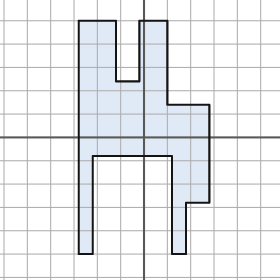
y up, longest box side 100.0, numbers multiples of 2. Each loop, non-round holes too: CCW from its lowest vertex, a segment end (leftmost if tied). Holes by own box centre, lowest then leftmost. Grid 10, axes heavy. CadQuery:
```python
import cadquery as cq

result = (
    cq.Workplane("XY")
    .moveTo(-28.0, -50.0)
    .lineTo(-22.0, -50.0)
    .lineTo(-22.0, -8.0)
    .lineTo(12.0, -8.0)
    .lineTo(12.0, -50.0)
    .lineTo(18.0, -50.0)
    .lineTo(18.0, -28.0)
    .lineTo(28.0, -28.0)
    .lineTo(28.0, 14.0)
    .lineTo(10.0, 14.0)
    .lineTo(10.0, 50.0)
    .lineTo(-2.0, 50.0)
    .lineTo(-2.0, 24.0)
    .lineTo(-12.0, 24.0)
    .lineTo(-12.0, 50.0)
    .lineTo(-28.0, 50.0)
    .close()
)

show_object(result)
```